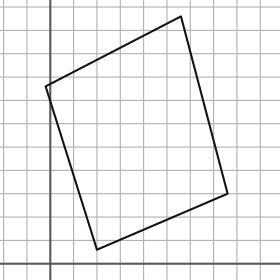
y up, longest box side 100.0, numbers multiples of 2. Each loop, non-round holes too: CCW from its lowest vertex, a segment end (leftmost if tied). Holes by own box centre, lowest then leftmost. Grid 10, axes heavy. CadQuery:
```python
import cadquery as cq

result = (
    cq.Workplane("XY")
    .moveTo(20.0, 6.0)
    .lineTo(76.0, 30.0)
    .lineTo(56.0, 106.0)
    .lineTo(-2.0, 76.0)
    .close()
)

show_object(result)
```